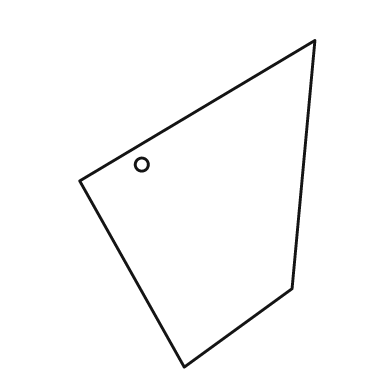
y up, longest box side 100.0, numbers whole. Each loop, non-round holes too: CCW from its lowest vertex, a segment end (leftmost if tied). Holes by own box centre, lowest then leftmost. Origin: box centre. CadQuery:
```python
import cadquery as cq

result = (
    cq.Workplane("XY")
    .moveTo(-4.0, -50.0)
    .lineTo(29.0, -26.0)
    .lineTo(36.0, 50.0)
    .lineTo(-36.0, 7.0)
    .close()
    .moveTo(-17.0, 12.0)
    .circle(2.0)
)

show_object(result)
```